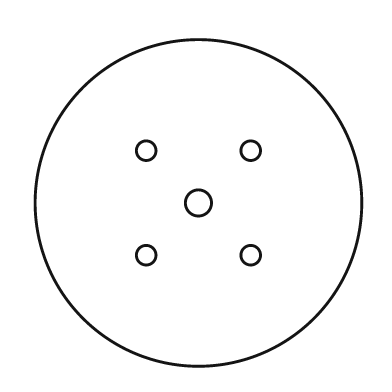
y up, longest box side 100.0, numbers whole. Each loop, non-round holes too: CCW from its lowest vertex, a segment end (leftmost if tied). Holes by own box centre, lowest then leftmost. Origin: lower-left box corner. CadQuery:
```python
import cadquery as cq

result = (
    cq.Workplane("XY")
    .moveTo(50.0, 50.0)
    .circle(50.0)
    .moveTo(34.0, 34.0)
    .circle(3.0)
    .moveTo(66.0, 34.0)
    .circle(3.0)
    .moveTo(50.0, 50.0)
    .circle(4.0)
    .moveTo(34.0, 66.0)
    .circle(3.0)
    .moveTo(66.0, 66.0)
    .circle(3.0)
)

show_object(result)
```